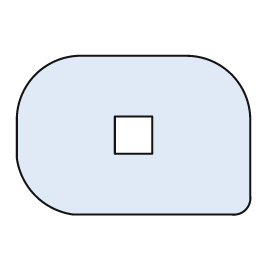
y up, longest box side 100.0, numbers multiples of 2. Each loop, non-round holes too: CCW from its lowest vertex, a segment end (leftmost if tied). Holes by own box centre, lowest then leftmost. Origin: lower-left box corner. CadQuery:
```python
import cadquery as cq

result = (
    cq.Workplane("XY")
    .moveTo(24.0, 0.0)
    .lineTo(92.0, 0.0)
    .threePointArc((98.0, 2.0), (100.0, 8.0))
    .lineTo(100.0, 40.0)
    .threePointArc((92.0, 60.0), (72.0, 68.0))
    .lineTo(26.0, 68.0)
    .threePointArc((8.0, 60.0), (0.0, 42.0))
    .lineTo(0.0, 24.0)
    .threePointArc((8.0, 8.0), (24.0, 0.0))
    .close()
    .moveTo(42.0, 26.0)
    .lineTo(58.0, 26.0)
    .lineTo(58.0, 42.0)
    .lineTo(42.0, 42.0)
    .close()
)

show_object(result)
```